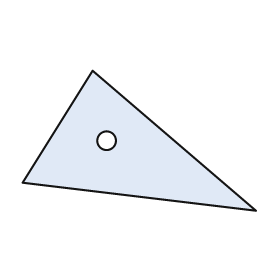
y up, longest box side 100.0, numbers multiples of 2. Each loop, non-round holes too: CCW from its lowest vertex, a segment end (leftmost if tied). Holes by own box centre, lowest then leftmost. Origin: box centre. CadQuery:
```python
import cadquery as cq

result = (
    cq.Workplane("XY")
    .moveTo(50.0, -30.0)
    .lineTo(-20.0, 30.0)
    .lineTo(-50.0, -18.0)
    .close()
    .moveTo(-14.0, 0.0)
    .circle(4.0)
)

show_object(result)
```